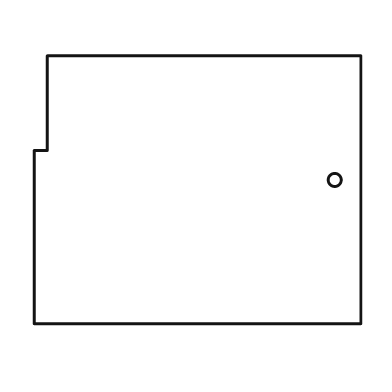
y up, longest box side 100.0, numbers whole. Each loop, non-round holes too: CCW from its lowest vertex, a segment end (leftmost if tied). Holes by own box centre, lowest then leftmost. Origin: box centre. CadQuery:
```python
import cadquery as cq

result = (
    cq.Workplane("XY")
    .moveTo(-50.0, -41.0)
    .lineTo(50.0, -41.0)
    .lineTo(50.0, 41.0)
    .lineTo(-46.0, 41.0)
    .lineTo(-46.0, 12.0)
    .lineTo(-50.0, 12.0)
    .close()
    .moveTo(42.0, 3.0)
    .circle(2.0)
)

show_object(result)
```